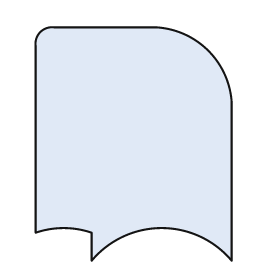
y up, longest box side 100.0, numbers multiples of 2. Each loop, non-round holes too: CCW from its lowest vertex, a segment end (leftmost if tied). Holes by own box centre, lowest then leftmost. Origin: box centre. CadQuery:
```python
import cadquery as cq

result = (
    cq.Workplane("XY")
    .moveTo(-18.0, -50.0)
    .threePointArc((12.0, -36.0), (42.0, -50.0))
    .lineTo(42.0, 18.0)
    .threePointArc((32.0, 40.0), (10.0, 50.0))
    .lineTo(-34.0, 50.0)
    .threePointArc((-40.0, 48.0), (-42.0, 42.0))
    .lineTo(-42.0, -38.0)
    .threePointArc((-30.0, -36.0), (-18.0, -38.0))
    .close()
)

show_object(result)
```